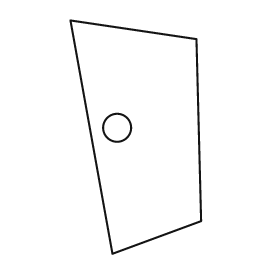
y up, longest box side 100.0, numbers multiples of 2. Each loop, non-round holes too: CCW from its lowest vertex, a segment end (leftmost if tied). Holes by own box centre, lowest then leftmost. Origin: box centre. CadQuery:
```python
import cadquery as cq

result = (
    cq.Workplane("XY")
    .moveTo(-10.0, -50.0)
    .lineTo(28.0, -36.0)
    .lineTo(26.0, 42.0)
    .lineTo(-28.0, 50.0)
    .close()
    .moveTo(-8.0, 4.0)
    .circle(6.0)
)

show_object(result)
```